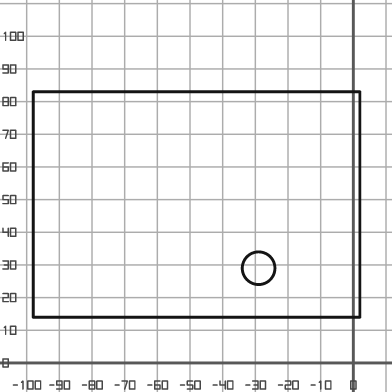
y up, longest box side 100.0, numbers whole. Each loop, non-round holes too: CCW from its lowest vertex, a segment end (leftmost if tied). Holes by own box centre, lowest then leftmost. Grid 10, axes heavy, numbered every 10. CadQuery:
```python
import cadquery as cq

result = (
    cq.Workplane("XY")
    .moveTo(-98.0, 14.0)
    .lineTo(2.0, 14.0)
    .lineTo(2.0, 83.0)
    .lineTo(-98.0, 83.0)
    .close()
    .moveTo(-29.0, 29.0)
    .circle(5.0)
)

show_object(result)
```